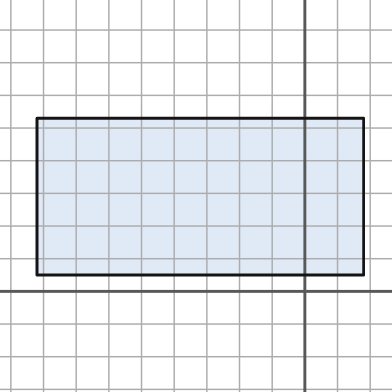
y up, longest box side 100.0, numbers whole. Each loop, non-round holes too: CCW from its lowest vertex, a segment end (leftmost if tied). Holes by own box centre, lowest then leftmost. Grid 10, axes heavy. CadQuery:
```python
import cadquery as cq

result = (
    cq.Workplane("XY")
    .moveTo(-82.0, 5.0)
    .lineTo(18.0, 5.0)
    .lineTo(18.0, 53.0)
    .lineTo(-82.0, 53.0)
    .close()
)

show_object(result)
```